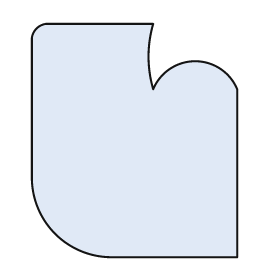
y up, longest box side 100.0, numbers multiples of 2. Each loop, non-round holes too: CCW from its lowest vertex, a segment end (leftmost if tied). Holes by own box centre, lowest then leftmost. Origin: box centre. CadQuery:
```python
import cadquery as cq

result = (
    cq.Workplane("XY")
    .moveTo(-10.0, -50.0)
    .lineTo(44.0, -50.0)
    .lineTo(44.0, 22.0)
    .threePointArc((26.0, 34.0), (8.0, 22.0))
    .threePointArc((6.0, 36.0), (8.0, 50.0))
    .lineTo(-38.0, 50.0)
    .threePointArc((-42.0, 48.0), (-44.0, 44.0))
    .lineTo(-44.0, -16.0)
    .threePointArc((-34.0, -40.0), (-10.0, -50.0))
    .close()
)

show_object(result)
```